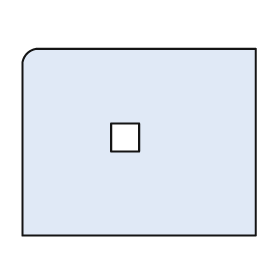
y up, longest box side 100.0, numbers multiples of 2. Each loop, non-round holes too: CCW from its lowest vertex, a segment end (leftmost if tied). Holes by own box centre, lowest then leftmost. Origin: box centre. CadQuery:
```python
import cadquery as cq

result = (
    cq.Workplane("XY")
    .moveTo(-50.0, -40.0)
    .lineTo(50.0, -40.0)
    .lineTo(50.0, 40.0)
    .lineTo(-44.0, 40.0)
    .threePointArc((-48.0, 38.0), (-50.0, 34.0))
    .close()
    .moveTo(-12.0, -4.0)
    .lineTo(0.0, -4.0)
    .lineTo(0.0, 8.0)
    .lineTo(-12.0, 8.0)
    .close()
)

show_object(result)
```